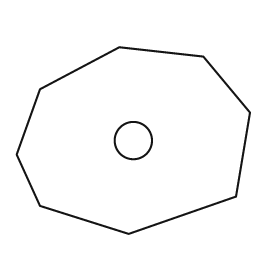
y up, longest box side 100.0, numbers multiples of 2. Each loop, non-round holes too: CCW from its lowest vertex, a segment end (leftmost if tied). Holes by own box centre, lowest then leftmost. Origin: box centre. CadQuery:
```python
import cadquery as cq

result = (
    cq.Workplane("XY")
    .moveTo(-2.0, -40.0)
    .lineTo(44.0, -24.0)
    .lineTo(50.0, 12.0)
    .lineTo(30.0, 36.0)
    .lineTo(-6.0, 40.0)
    .lineTo(-40.0, 22.0)
    .lineTo(-50.0, -6.0)
    .lineTo(-40.0, -28.0)
    .close()
    .moveTo(0.0, 0.0)
    .circle(8.0)
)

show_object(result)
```